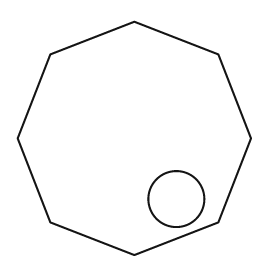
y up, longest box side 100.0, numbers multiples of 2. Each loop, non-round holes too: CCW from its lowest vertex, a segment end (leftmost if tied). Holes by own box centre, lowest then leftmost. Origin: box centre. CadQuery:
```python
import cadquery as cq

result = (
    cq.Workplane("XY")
    .moveTo(0.0, -50.0)
    .lineTo(36.0, -36.0)
    .lineTo(50.0, 0.0)
    .lineTo(36.0, 36.0)
    .lineTo(0.0, 50.0)
    .lineTo(-36.0, 36.0)
    .lineTo(-50.0, 0.0)
    .lineTo(-36.0, -36.0)
    .close()
    .moveTo(18.0, -26.0)
    .circle(12.0)
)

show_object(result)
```